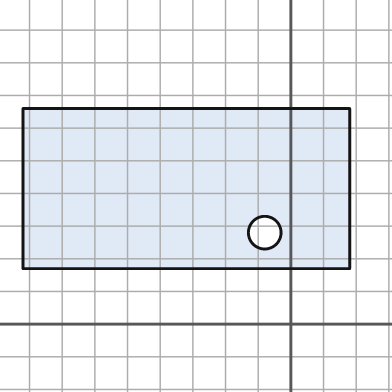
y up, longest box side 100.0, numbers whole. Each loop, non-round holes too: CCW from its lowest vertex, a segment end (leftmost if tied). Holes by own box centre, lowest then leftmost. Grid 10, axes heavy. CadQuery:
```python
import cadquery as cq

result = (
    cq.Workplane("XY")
    .moveTo(-82.0, 17.0)
    .lineTo(18.0, 17.0)
    .lineTo(18.0, 66.0)
    .lineTo(-82.0, 66.0)
    .close()
    .moveTo(-8.0, 28.0)
    .circle(5.0)
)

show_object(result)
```